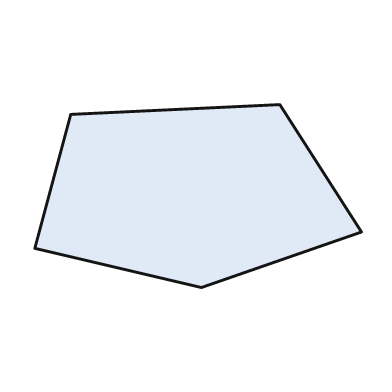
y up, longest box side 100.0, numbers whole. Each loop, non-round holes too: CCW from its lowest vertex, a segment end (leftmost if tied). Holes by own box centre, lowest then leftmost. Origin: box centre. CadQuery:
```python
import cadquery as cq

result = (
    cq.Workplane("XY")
    .moveTo(1.0, -28.0)
    .lineTo(50.0, -11.0)
    .lineTo(25.0, 28.0)
    .lineTo(-39.0, 25.0)
    .lineTo(-50.0, -16.0)
    .close()
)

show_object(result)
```